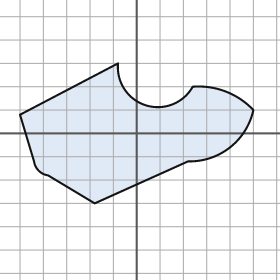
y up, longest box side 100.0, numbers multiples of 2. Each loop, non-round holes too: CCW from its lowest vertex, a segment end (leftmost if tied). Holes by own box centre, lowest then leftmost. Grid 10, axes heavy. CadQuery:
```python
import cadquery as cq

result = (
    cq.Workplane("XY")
    .moveTo(-18.0, -30.0)
    .lineTo(22.0, -12.0)
    .threePointArc((40.0, -6.0), (50.0, 10.0))
    .threePointArc((38.0, 18.0), (24.0, 20.0))
    .threePointArc((4.0, 12.0), (-8.0, 30.0))
    .lineTo(-50.0, 8.0)
    .lineTo(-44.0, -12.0)
    .threePointArc((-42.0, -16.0), (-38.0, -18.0))
    .close()
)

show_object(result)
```